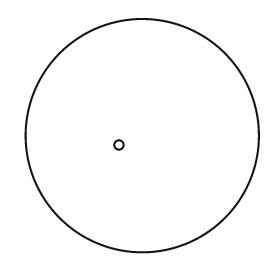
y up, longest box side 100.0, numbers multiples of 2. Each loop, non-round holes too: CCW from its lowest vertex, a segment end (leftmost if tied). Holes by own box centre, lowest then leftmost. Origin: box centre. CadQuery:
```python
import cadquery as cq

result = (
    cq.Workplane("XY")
    .moveTo(0.0, 0.0)
    .circle(50.0)
    .moveTo(-10.0, -4.0)
    .circle(2.0)
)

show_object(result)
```